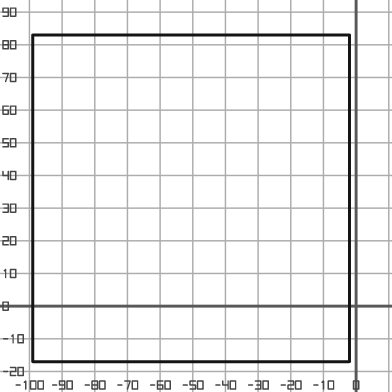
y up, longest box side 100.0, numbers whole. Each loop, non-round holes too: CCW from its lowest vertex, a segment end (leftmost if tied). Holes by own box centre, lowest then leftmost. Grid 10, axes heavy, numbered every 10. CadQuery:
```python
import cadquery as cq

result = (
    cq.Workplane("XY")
    .moveTo(-99.0, -17.0)
    .lineTo(-2.0, -17.0)
    .lineTo(-2.0, 83.0)
    .lineTo(-99.0, 83.0)
    .close()
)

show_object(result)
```